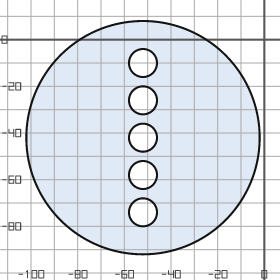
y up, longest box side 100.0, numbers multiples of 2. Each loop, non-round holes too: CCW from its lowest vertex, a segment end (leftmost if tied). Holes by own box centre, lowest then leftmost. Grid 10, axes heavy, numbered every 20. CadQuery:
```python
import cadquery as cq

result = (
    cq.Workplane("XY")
    .moveTo(-52.0, -42.0)
    .circle(50.0)
    .moveTo(-52.0, -74.0)
    .circle(6.0)
    .moveTo(-52.0, -58.0)
    .circle(6.0)
    .moveTo(-52.0, -42.0)
    .circle(6.0)
    .moveTo(-52.0, -26.0)
    .circle(6.0)
    .moveTo(-52.0, -10.0)
    .circle(6.0)
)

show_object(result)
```